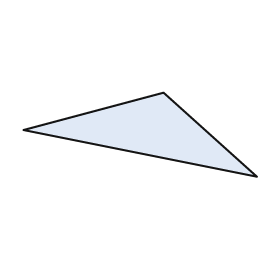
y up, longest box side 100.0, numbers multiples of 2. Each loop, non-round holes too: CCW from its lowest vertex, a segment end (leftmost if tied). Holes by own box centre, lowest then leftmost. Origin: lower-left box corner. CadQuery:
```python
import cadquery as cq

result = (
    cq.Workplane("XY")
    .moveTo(100.0, 0.0)
    .lineTo(60.0, 36.0)
    .lineTo(0.0, 20.0)
    .close()
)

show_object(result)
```